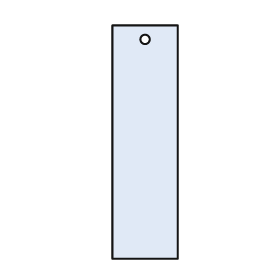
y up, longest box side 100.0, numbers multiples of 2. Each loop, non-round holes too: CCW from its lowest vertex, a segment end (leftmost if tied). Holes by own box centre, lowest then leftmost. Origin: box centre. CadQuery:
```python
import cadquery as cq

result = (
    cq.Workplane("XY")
    .moveTo(-14.0, -50.0)
    .lineTo(14.0, -50.0)
    .lineTo(14.0, 50.0)
    .lineTo(-14.0, 50.0)
    .close()
    .moveTo(0.0, 44.0)
    .circle(2.0)
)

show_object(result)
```